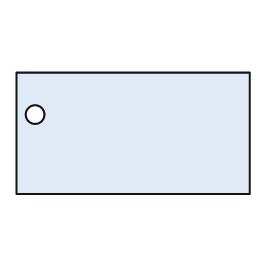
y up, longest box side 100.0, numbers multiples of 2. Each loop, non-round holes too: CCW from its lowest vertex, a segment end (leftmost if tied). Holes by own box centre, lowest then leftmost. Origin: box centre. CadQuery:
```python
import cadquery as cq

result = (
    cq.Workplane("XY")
    .moveTo(-50.0, -26.0)
    .lineTo(50.0, -26.0)
    .lineTo(50.0, 26.0)
    .lineTo(-50.0, 26.0)
    .close()
    .moveTo(-42.0, 8.0)
    .circle(4.0)
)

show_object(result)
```